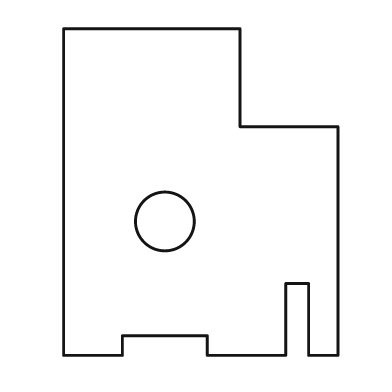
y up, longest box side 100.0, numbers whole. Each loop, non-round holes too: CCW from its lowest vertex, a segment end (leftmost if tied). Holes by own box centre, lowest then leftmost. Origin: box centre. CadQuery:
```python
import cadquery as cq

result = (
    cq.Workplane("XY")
    .moveTo(-42.0, -50.0)
    .lineTo(-24.0, -50.0)
    .lineTo(-24.0, -44.0)
    .lineTo(2.0, -44.0)
    .lineTo(2.0, -50.0)
    .lineTo(26.0, -50.0)
    .lineTo(26.0, -28.0)
    .lineTo(33.0, -28.0)
    .lineTo(33.0, -50.0)
    .lineTo(42.0, -50.0)
    .lineTo(42.0, 20.0)
    .lineTo(12.0, 20.0)
    .lineTo(12.0, 50.0)
    .lineTo(-42.0, 50.0)
    .close()
    .moveTo(-11.0, -9.0)
    .circle(9.0)
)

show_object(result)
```